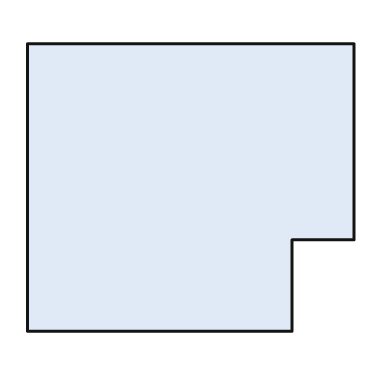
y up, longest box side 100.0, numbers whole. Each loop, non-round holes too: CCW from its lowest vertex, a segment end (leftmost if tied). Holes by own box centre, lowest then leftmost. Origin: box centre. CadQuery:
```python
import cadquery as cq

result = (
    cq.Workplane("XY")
    .moveTo(-50.0, -44.0)
    .lineTo(31.0, -44.0)
    .lineTo(31.0, -16.0)
    .lineTo(50.0, -16.0)
    .lineTo(50.0, 44.0)
    .lineTo(-50.0, 44.0)
    .close()
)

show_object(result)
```